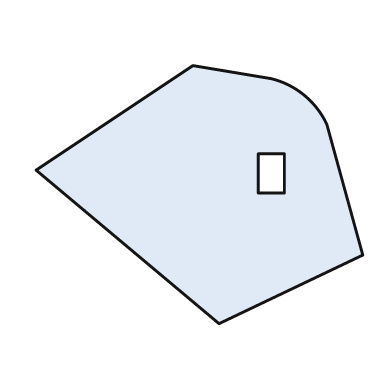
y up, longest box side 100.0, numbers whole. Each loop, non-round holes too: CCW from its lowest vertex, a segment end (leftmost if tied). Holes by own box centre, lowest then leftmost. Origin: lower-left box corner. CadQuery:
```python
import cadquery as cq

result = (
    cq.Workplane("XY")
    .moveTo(56.0, 0.0)
    .lineTo(100.0, 21.0)
    .lineTo(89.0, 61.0)
    .threePointArc((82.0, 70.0), (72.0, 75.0))
    .lineTo(48.0, 79.0)
    .lineTo(0.0, 47.0)
    .close()
    .moveTo(68.0, 40.0)
    .lineTo(76.0, 40.0)
    .lineTo(76.0, 52.0)
    .lineTo(68.0, 52.0)
    .close()
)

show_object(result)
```